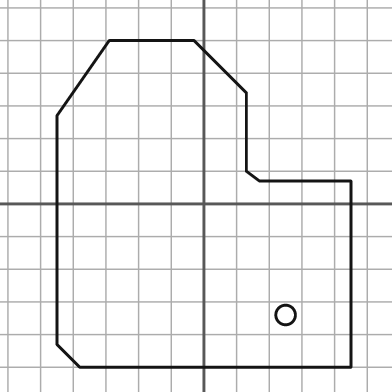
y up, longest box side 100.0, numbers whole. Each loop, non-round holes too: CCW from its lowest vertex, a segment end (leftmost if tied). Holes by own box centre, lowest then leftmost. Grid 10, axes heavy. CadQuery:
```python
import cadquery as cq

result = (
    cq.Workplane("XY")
    .moveTo(-38.0, -50.0)
    .lineTo(45.0, -50.0)
    .lineTo(45.0, 7.0)
    .lineTo(17.0, 7.0)
    .lineTo(13.0, 10.0)
    .lineTo(13.0, 34.0)
    .lineTo(-3.0, 50.0)
    .lineTo(-29.0, 50.0)
    .lineTo(-45.0, 27.0)
    .lineTo(-45.0, -43.0)
    .close()
    .moveTo(25.0, -34.0)
    .circle(3.0)
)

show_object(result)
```